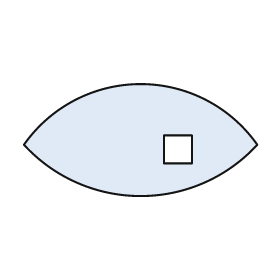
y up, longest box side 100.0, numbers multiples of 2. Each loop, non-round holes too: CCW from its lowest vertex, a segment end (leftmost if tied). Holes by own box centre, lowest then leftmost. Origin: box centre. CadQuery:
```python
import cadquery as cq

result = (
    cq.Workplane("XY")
    .moveTo(-50.0, -2.0)
    .threePointArc((0.0, -24.0), (50.0, -2.0))
    .threePointArc((0.0, 24.0), (-50.0, -2.0))
    .close()
    .moveTo(10.0, -10.0)
    .lineTo(22.0, -10.0)
    .lineTo(22.0, 2.0)
    .lineTo(10.0, 2.0)
    .close()
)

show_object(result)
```